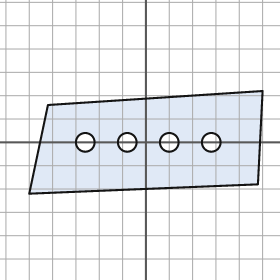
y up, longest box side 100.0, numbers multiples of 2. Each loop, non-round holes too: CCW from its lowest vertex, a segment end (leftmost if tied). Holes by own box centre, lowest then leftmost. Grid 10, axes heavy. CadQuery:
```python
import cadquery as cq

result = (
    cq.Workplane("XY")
    .moveTo(-50.0, -22.0)
    .lineTo(48.0, -18.0)
    .lineTo(50.0, 22.0)
    .lineTo(-42.0, 16.0)
    .close()
    .moveTo(-26.0, 0.0)
    .circle(4.0)
    .moveTo(-8.0, 0.0)
    .circle(4.0)
    .moveTo(10.0, 0.0)
    .circle(4.0)
    .moveTo(28.0, 0.0)
    .circle(4.0)
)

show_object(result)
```